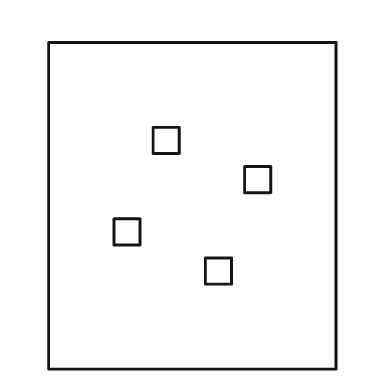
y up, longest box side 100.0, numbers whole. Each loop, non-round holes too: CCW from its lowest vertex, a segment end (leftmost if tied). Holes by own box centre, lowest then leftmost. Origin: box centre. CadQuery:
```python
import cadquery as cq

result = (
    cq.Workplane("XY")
    .moveTo(-44.0, -50.0)
    .lineTo(44.0, -50.0)
    .lineTo(44.0, 50.0)
    .lineTo(-44.0, 50.0)
    .close()
    .moveTo(4.0, -24.0)
    .lineTo(12.0, -24.0)
    .lineTo(12.0, -16.0)
    .lineTo(4.0, -16.0)
    .close()
    .moveTo(-24.0, -12.0)
    .lineTo(-16.0, -12.0)
    .lineTo(-16.0, -4.0)
    .lineTo(-24.0, -4.0)
    .close()
    .moveTo(16.0, 4.0)
    .lineTo(24.0, 4.0)
    .lineTo(24.0, 12.0)
    .lineTo(16.0, 12.0)
    .close()
    .moveTo(-12.0, 16.0)
    .lineTo(-4.0, 16.0)
    .lineTo(-4.0, 24.0)
    .lineTo(-12.0, 24.0)
    .close()
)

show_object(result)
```